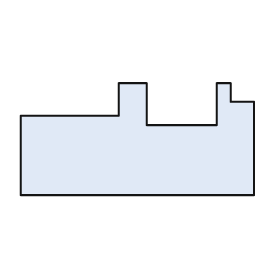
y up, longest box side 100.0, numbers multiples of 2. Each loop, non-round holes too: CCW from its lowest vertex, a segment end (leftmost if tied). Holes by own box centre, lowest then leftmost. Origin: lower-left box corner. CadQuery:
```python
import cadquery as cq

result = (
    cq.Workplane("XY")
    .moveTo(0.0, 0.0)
    .lineTo(100.0, 0.0)
    .lineTo(100.0, 40.0)
    .lineTo(90.0, 40.0)
    .lineTo(90.0, 48.0)
    .lineTo(84.0, 48.0)
    .lineTo(84.0, 30.0)
    .lineTo(54.0, 30.0)
    .lineTo(54.0, 48.0)
    .lineTo(42.0, 48.0)
    .lineTo(42.0, 34.0)
    .lineTo(0.0, 34.0)
    .close()
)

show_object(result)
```